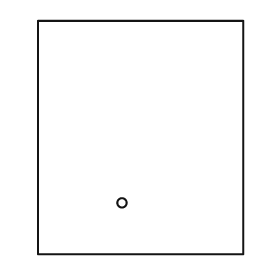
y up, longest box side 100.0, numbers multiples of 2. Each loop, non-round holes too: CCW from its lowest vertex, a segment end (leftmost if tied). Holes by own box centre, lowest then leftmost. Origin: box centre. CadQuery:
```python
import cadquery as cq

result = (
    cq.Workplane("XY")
    .moveTo(-44.0, -50.0)
    .lineTo(44.0, -50.0)
    .lineTo(44.0, 50.0)
    .lineTo(-44.0, 50.0)
    .close()
    .moveTo(-8.0, -28.0)
    .circle(2.0)
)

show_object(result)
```